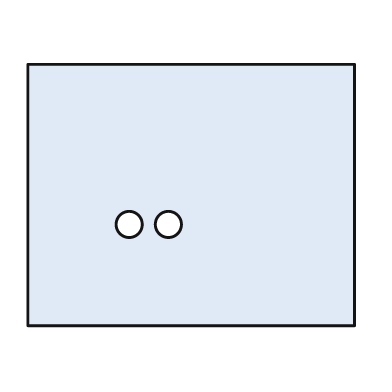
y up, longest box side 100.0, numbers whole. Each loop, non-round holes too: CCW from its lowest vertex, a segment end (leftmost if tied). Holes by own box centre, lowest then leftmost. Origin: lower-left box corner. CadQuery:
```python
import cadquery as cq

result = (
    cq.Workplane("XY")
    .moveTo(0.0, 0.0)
    .lineTo(100.0, 0.0)
    .lineTo(100.0, 80.0)
    .lineTo(0.0, 80.0)
    .close()
    .moveTo(31.0, 31.0)
    .circle(4.0)
    .moveTo(43.0, 31.0)
    .circle(4.0)
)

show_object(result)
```